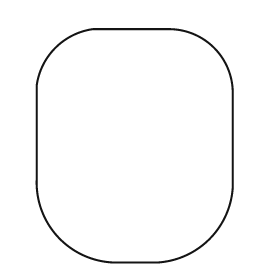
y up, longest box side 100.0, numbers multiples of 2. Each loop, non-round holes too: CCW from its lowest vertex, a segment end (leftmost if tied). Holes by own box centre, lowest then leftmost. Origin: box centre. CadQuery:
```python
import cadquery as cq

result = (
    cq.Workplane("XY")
    .moveTo(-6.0, -50.0)
    .lineTo(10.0, -50.0)
    .threePointArc((32.0, -40.0), (42.0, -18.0))
    .lineTo(42.0, 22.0)
    .threePointArc((34.0, 42.0), (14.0, 50.0))
    .lineTo(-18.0, 50.0)
    .threePointArc((-34.0, 42.0), (-42.0, 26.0))
    .lineTo(-42.0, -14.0)
    .threePointArc((-32.0, -40.0), (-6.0, -50.0))
    .close()
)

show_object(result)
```